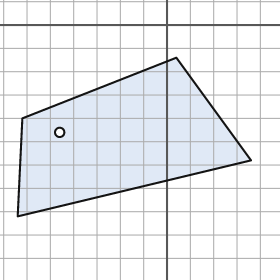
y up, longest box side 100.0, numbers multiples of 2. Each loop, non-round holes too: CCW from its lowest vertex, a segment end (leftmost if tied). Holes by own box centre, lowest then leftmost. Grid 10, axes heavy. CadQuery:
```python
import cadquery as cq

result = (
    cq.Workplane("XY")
    .moveTo(-64.0, -82.0)
    .lineTo(36.0, -58.0)
    .lineTo(4.0, -14.0)
    .lineTo(-62.0, -40.0)
    .close()
    .moveTo(-46.0, -46.0)
    .circle(2.0)
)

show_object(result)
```